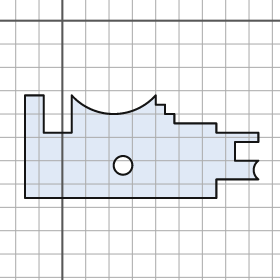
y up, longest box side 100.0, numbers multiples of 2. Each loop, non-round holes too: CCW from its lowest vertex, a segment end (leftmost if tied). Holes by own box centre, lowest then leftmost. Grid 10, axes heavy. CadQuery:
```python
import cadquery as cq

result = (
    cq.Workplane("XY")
    .moveTo(-16.0, -76.0)
    .lineTo(66.0, -76.0)
    .lineTo(66.0, -68.0)
    .lineTo(84.0, -68.0)
    .threePointArc((82.0, -64.0), (84.0, -60.0))
    .lineTo(74.0, -60.0)
    .lineTo(74.0, -52.0)
    .lineTo(84.0, -52.0)
    .lineTo(84.0, -48.0)
    .lineTo(66.0, -48.0)
    .lineTo(66.0, -44.0)
    .lineTo(48.0, -44.0)
    .lineTo(48.0, -40.0)
    .lineTo(44.0, -40.0)
    .lineTo(44.0, -36.0)
    .lineTo(40.0, -36.0)
    .lineTo(40.0, -32.0)
    .threePointArc((22.0, -40.0), (4.0, -32.0))
    .lineTo(4.0, -48.0)
    .lineTo(-8.0, -48.0)
    .lineTo(-8.0, -32.0)
    .lineTo(-16.0, -32.0)
    .close()
    .moveTo(26.0, -62.0)
    .circle(4.0)
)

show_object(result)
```